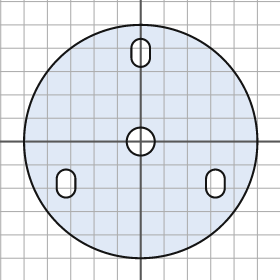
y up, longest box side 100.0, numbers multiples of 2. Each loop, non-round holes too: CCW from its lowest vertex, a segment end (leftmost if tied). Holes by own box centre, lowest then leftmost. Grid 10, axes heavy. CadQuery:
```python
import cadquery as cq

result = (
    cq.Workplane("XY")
    .moveTo(0.0, 0.0)
    .circle(50.0)
    .moveTo(-36.0, -20.0)
    .threePointArc((-32.0, -24.0), (-28.0, -20.0))
    .lineTo(-28.0, -16.0)
    .threePointArc((-32.0, -12.0), (-36.0, -16.0))
    .close()
    .moveTo(28.0, -20.0)
    .threePointArc((32.0, -24.0), (36.0, -20.0))
    .lineTo(36.0, -16.0)
    .threePointArc((32.0, -12.0), (28.0, -16.0))
    .close()
    .moveTo(0.0, 0.0)
    .circle(6.0)
    .moveTo(-4.0, 36.0)
    .threePointArc((0.0, 32.0), (4.0, 36.0))
    .lineTo(4.0, 40.0)
    .threePointArc((0.0, 44.0), (-4.0, 40.0))
    .close()
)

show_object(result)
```